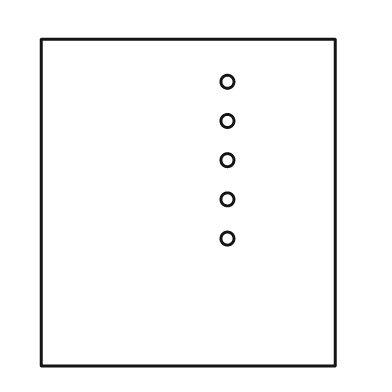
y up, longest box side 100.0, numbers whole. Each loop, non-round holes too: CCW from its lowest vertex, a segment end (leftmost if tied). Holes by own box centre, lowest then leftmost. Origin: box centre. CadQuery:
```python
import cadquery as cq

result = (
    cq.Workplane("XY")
    .moveTo(-45.0, -50.0)
    .lineTo(45.0, -50.0)
    .lineTo(45.0, 50.0)
    .lineTo(-45.0, 50.0)
    .close()
    .moveTo(12.0, -11.0)
    .circle(2.0)
    .moveTo(12.0, 1.0)
    .circle(2.0)
    .moveTo(12.0, 13.0)
    .circle(2.0)
    .moveTo(12.0, 25.0)
    .circle(2.0)
    .moveTo(12.0, 37.0)
    .circle(2.0)
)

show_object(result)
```